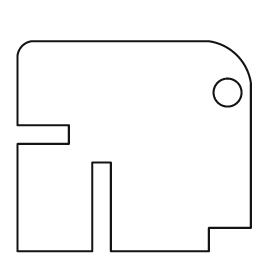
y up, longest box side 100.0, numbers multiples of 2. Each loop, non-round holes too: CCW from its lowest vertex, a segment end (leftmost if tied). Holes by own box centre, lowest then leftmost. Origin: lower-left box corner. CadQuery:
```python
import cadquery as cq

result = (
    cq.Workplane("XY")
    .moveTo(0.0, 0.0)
    .lineTo(32.0, 0.0)
    .lineTo(32.0, 38.0)
    .lineTo(40.0, 38.0)
    .lineTo(40.0, 0.0)
    .lineTo(82.0, 0.0)
    .lineTo(82.0, 10.0)
    .lineTo(100.0, 10.0)
    .lineTo(100.0, 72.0)
    .threePointArc((94.0, 84.0), (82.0, 90.0))
    .lineTo(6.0, 90.0)
    .threePointArc((2.0, 88.0), (0.0, 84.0))
    .lineTo(0.0, 54.0)
    .lineTo(22.0, 54.0)
    .lineTo(22.0, 46.0)
    .lineTo(0.0, 46.0)
    .close()
    .moveTo(90.0, 68.0)
    .circle(6.0)
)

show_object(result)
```